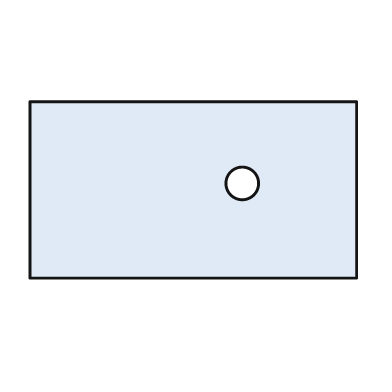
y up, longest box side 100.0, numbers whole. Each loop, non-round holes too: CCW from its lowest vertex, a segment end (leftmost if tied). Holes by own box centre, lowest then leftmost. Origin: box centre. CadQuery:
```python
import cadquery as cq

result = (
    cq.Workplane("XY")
    .moveTo(-50.0, -27.0)
    .lineTo(50.0, -27.0)
    .lineTo(50.0, 27.0)
    .lineTo(-50.0, 27.0)
    .close()
    .moveTo(15.0, 2.0)
    .circle(5.0)
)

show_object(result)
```